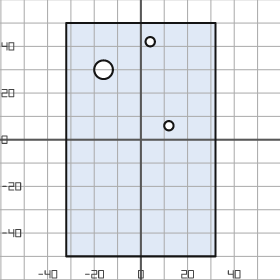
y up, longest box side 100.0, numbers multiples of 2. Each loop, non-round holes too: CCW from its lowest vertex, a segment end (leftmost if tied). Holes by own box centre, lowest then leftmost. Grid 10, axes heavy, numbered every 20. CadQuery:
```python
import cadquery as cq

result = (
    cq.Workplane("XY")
    .moveTo(-32.0, -50.0)
    .lineTo(32.0, -50.0)
    .lineTo(32.0, 50.0)
    .lineTo(-32.0, 50.0)
    .close()
    .moveTo(12.0, 6.0)
    .circle(2.0)
    .moveTo(-16.0, 30.0)
    .circle(4.0)
    .moveTo(4.0, 42.0)
    .circle(2.0)
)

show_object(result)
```